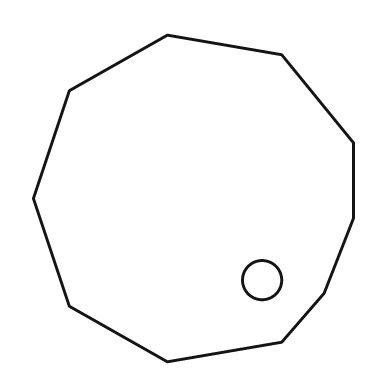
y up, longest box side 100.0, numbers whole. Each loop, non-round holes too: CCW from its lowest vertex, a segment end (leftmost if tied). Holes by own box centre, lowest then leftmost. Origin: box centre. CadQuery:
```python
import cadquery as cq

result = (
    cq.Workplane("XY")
    .moveTo(-8.0, -50.0)
    .lineTo(27.0, -44.0)
    .lineTo(40.0, -29.0)
    .lineTo(49.0, -6.0)
    .lineTo(49.0, 17.0)
    .lineTo(27.0, 44.0)
    .lineTo(-8.0, 50.0)
    .lineTo(-38.0, 33.0)
    .lineTo(-49.0, 0.0)
    .lineTo(-38.0, -33.0)
    .close()
    .moveTo(21.0, -25.0)
    .circle(6.0)
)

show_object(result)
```